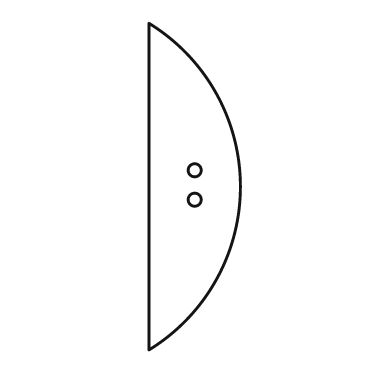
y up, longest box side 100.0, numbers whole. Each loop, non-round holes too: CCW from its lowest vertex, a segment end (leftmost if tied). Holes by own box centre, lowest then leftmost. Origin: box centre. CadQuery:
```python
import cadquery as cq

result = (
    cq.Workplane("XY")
    .moveTo(-14.0, -50.0)
    .threePointArc((14.0, 0.0), (-14.0, 50.0))
    .close()
    .moveTo(0.0, -4.0)
    .circle(2.0)
    .moveTo(0.0, 5.0)
    .circle(2.0)
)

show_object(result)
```